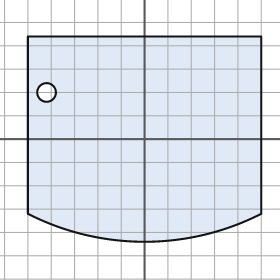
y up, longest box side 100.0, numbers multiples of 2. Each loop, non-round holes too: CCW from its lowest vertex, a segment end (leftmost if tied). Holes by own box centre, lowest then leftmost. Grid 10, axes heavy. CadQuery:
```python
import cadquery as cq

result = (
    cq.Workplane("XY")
    .moveTo(-50.0, -32.0)
    .threePointArc((0.0, -44.0), (50.0, -32.0))
    .lineTo(50.0, 44.0)
    .lineTo(-50.0, 44.0)
    .close()
    .moveTo(-42.0, 20.0)
    .circle(4.0)
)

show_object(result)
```